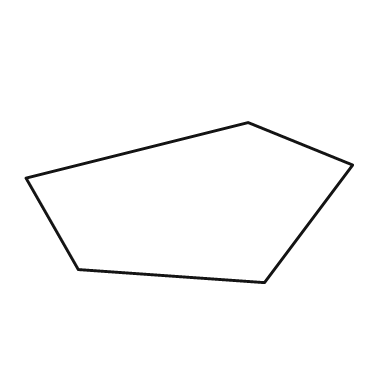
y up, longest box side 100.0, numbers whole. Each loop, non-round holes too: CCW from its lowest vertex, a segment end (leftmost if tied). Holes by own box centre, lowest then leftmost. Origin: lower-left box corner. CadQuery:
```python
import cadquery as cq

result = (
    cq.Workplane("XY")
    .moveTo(73.0, 0.0)
    .lineTo(100.0, 36.0)
    .lineTo(68.0, 49.0)
    .lineTo(0.0, 32.0)
    .lineTo(16.0, 4.0)
    .close()
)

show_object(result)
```